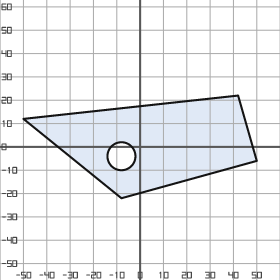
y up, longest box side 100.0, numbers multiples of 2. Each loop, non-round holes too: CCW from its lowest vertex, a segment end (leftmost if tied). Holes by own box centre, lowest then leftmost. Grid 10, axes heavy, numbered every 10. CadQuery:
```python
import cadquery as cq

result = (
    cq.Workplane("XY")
    .moveTo(-8.0, -22.0)
    .lineTo(50.0, -6.0)
    .lineTo(42.0, 22.0)
    .lineTo(-50.0, 12.0)
    .close()
    .moveTo(-8.0, -4.0)
    .circle(6.0)
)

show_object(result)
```